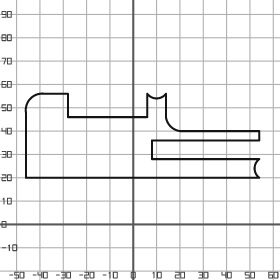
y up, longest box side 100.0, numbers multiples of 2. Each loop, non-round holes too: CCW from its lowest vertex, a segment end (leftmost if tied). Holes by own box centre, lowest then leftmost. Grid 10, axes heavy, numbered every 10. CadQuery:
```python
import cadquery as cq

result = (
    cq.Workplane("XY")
    .moveTo(-46.0, 20.0)
    .lineTo(54.0, 20.0)
    .threePointArc((52.0, 24.0), (54.0, 28.0))
    .lineTo(8.0, 28.0)
    .lineTo(8.0, 36.0)
    .lineTo(54.0, 36.0)
    .lineTo(54.0, 40.0)
    .lineTo(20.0, 40.0)
    .threePointArc((16.0, 42.0), (14.0, 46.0))
    .lineTo(14.0, 56.0)
    .threePointArc((10.0, 54.0), (6.0, 56.0))
    .lineTo(6.0, 46.0)
    .lineTo(-28.0, 46.0)
    .lineTo(-28.0, 56.0)
    .lineTo(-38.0, 56.0)
    .threePointArc((-44.0, 54.0), (-46.0, 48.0))
    .close()
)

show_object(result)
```